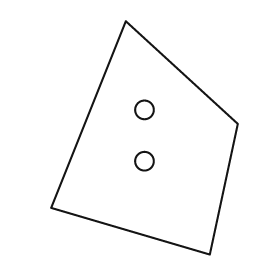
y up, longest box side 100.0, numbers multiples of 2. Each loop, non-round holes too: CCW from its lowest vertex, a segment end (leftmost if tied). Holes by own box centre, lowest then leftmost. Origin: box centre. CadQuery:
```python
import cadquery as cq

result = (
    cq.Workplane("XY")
    .moveTo(28.0, -50.0)
    .lineTo(40.0, 6.0)
    .lineTo(-8.0, 50.0)
    .lineTo(-40.0, -30.0)
    .close()
    .moveTo(0.0, -10.0)
    .circle(4.0)
    .moveTo(0.0, 12.0)
    .circle(4.0)
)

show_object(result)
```